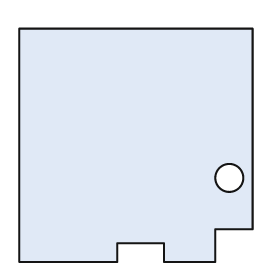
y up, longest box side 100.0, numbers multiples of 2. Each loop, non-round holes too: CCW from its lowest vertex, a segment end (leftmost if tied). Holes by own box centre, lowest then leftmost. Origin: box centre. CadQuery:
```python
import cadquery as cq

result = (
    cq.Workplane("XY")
    .moveTo(-50.0, -50.0)
    .lineTo(-8.0, -50.0)
    .lineTo(-8.0, -42.0)
    .lineTo(12.0, -42.0)
    .lineTo(12.0, -50.0)
    .lineTo(34.0, -50.0)
    .lineTo(34.0, -36.0)
    .lineTo(50.0, -36.0)
    .lineTo(50.0, 50.0)
    .lineTo(-50.0, 50.0)
    .close()
    .moveTo(40.0, -14.0)
    .circle(6.0)
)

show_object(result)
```